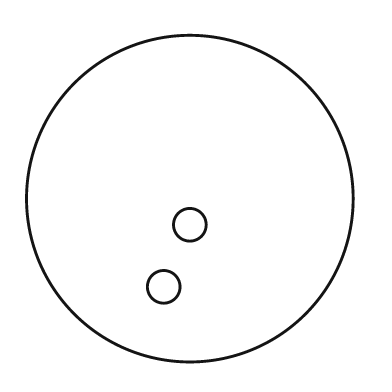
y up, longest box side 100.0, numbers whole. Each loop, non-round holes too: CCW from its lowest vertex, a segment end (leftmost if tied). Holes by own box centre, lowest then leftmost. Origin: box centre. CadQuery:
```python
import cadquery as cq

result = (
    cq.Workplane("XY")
    .moveTo(0.0, 0.0)
    .circle(50.0)
    .moveTo(-8.0, -27.0)
    .circle(5.0)
    .moveTo(0.0, -8.0)
    .circle(5.0)
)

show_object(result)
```